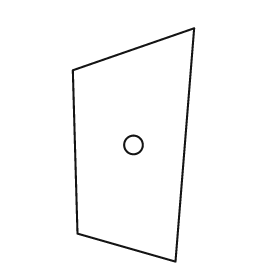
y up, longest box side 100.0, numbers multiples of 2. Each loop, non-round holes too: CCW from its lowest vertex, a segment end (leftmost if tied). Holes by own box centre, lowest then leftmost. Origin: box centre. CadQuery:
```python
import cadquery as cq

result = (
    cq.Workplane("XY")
    .moveTo(18.0, -50.0)
    .lineTo(26.0, 50.0)
    .lineTo(-26.0, 32.0)
    .lineTo(-24.0, -38.0)
    .close()
    .moveTo(0.0, 0.0)
    .circle(4.0)
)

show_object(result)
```